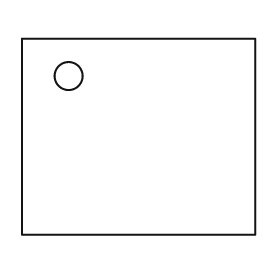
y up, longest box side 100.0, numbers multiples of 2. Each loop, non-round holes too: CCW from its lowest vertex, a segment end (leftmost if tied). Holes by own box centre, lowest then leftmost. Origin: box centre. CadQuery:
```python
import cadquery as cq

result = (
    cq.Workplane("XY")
    .moveTo(-50.0, -42.0)
    .lineTo(50.0, -42.0)
    .lineTo(50.0, 42.0)
    .lineTo(-50.0, 42.0)
    .close()
    .moveTo(-30.0, 26.0)
    .circle(6.0)
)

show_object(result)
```